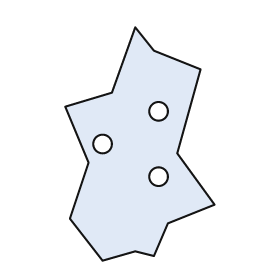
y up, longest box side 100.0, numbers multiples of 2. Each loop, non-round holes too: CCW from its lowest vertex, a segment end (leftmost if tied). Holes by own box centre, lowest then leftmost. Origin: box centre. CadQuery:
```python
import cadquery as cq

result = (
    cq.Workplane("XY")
    .moveTo(-16.0, -50.0)
    .lineTo(-2.0, -46.0)
    .lineTo(6.0, -48.0)
    .lineTo(12.0, -34.0)
    .lineTo(32.0, -26.0)
    .lineTo(16.0, -4.0)
    .lineTo(26.0, 32.0)
    .lineTo(6.0, 40.0)
    .lineTo(-2.0, 50.0)
    .lineTo(-12.0, 22.0)
    .lineTo(-32.0, 16.0)
    .lineTo(-22.0, -8.0)
    .lineTo(-30.0, -32.0)
    .close()
    .moveTo(8.0, -14.0)
    .circle(4.0)
    .moveTo(-16.0, 0.0)
    .circle(4.0)
    .moveTo(8.0, 14.0)
    .circle(4.0)
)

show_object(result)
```